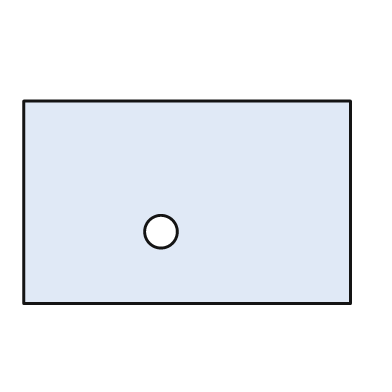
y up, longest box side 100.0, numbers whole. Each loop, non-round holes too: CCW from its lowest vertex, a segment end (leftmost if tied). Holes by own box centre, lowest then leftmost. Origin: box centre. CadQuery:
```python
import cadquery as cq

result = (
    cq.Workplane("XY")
    .moveTo(-50.0, -31.0)
    .lineTo(50.0, -31.0)
    .lineTo(50.0, 31.0)
    .lineTo(-50.0, 31.0)
    .close()
    .moveTo(-8.0, -9.0)
    .circle(5.0)
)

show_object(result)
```